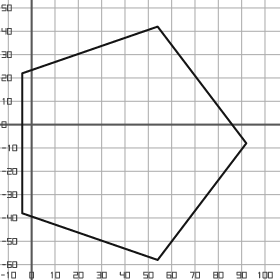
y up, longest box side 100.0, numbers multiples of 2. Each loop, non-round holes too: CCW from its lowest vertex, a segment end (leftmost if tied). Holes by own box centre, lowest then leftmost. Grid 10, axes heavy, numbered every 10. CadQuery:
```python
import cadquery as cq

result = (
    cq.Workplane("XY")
    .moveTo(54.0, -58.0)
    .lineTo(92.0, -8.0)
    .lineTo(54.0, 42.0)
    .lineTo(-4.0, 22.0)
    .lineTo(-4.0, -38.0)
    .close()
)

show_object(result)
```